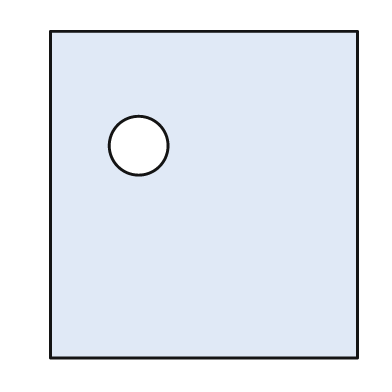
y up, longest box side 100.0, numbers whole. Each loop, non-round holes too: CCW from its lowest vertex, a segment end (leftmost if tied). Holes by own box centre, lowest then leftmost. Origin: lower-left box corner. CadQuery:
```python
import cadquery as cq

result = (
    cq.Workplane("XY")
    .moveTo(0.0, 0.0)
    .lineTo(94.0, 0.0)
    .lineTo(94.0, 100.0)
    .lineTo(0.0, 100.0)
    .close()
    .moveTo(27.0, 65.0)
    .circle(9.0)
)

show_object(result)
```